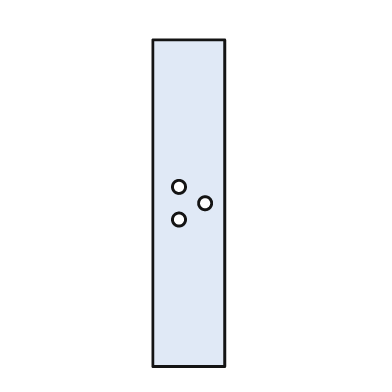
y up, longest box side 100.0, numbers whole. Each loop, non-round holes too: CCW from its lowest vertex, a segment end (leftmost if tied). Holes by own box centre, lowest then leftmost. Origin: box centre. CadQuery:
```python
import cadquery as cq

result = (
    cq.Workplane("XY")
    .moveTo(-11.0, -50.0)
    .lineTo(11.0, -50.0)
    .lineTo(11.0, 50.0)
    .lineTo(-11.0, 50.0)
    .close()
    .moveTo(-3.0, -5.0)
    .circle(2.0)
    .moveTo(5.0, 0.0)
    .circle(2.0)
    .moveTo(-3.0, 5.0)
    .circle(2.0)
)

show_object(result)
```